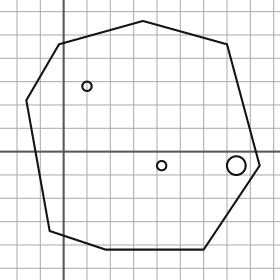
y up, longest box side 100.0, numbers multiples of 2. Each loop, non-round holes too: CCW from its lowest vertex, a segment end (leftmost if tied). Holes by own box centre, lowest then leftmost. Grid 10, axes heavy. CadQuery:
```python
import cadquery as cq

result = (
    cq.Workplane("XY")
    .moveTo(18.0, -42.0)
    .lineTo(60.0, -42.0)
    .lineTo(84.0, -6.0)
    .lineTo(70.0, 46.0)
    .lineTo(34.0, 56.0)
    .lineTo(-2.0, 46.0)
    .lineTo(-16.0, 22.0)
    .lineTo(-6.0, -34.0)
    .close()
    .moveTo(42.0, -6.0)
    .circle(2.0)
    .moveTo(74.0, -6.0)
    .circle(4.0)
    .moveTo(10.0, 28.0)
    .circle(2.0)
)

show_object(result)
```